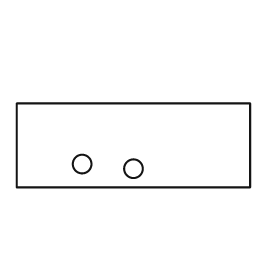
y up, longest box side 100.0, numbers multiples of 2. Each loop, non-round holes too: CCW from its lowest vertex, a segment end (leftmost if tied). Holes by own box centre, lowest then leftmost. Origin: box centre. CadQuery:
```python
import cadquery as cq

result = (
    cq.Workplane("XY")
    .moveTo(-50.0, -18.0)
    .lineTo(50.0, -18.0)
    .lineTo(50.0, 18.0)
    .lineTo(-50.0, 18.0)
    .close()
    .moveTo(0.0, -10.0)
    .circle(4.0)
    .moveTo(-22.0, -8.0)
    .circle(4.0)
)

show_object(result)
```